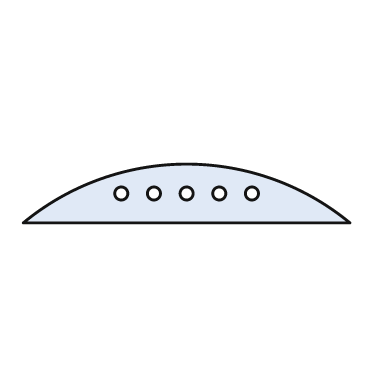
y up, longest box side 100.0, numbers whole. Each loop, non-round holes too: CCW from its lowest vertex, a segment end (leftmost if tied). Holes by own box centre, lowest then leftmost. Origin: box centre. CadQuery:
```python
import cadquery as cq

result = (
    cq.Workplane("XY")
    .moveTo(-50.0, -9.0)
    .lineTo(50.0, -9.0)
    .threePointArc((0.0, 9.0), (-50.0, -9.0))
    .close()
    .moveTo(-20.0, 0.0)
    .circle(2.0)
    .moveTo(-10.0, 0.0)
    .circle(2.0)
    .moveTo(0.0, 0.0)
    .circle(2.0)
    .moveTo(10.0, 0.0)
    .circle(2.0)
    .moveTo(20.0, 0.0)
    .circle(2.0)
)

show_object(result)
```